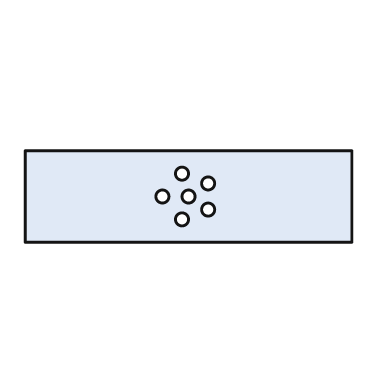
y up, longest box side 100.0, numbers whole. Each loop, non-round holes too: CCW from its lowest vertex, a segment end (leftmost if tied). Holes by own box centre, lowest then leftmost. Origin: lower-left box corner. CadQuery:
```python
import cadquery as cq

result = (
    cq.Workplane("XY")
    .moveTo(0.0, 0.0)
    .lineTo(100.0, 0.0)
    .lineTo(100.0, 28.0)
    .lineTo(0.0, 28.0)
    .close()
    .moveTo(48.0, 7.0)
    .circle(2.0)
    .moveTo(56.0, 10.0)
    .circle(2.0)
    .moveTo(42.0, 14.0)
    .circle(2.0)
    .moveTo(50.0, 14.0)
    .circle(2.0)
    .moveTo(56.0, 18.0)
    .circle(2.0)
    .moveTo(48.0, 21.0)
    .circle(2.0)
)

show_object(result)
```